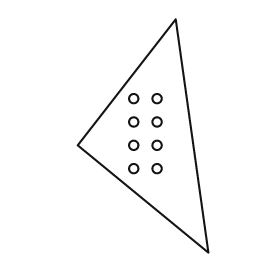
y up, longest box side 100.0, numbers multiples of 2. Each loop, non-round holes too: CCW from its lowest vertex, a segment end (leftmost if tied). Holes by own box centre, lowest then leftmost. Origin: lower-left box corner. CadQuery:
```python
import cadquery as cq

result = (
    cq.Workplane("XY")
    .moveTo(56.0, 0.0)
    .lineTo(42.0, 100.0)
    .lineTo(0.0, 46.0)
    .close()
    .moveTo(24.0, 36.0)
    .circle(2.0)
    .moveTo(34.0, 36.0)
    .circle(2.0)
    .moveTo(24.0, 46.0)
    .circle(2.0)
    .moveTo(34.0, 46.0)
    .circle(2.0)
    .moveTo(24.0, 56.0)
    .circle(2.0)
    .moveTo(34.0, 56.0)
    .circle(2.0)
    .moveTo(24.0, 66.0)
    .circle(2.0)
    .moveTo(34.0, 66.0)
    .circle(2.0)
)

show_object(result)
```